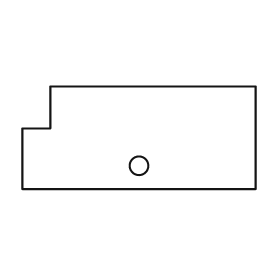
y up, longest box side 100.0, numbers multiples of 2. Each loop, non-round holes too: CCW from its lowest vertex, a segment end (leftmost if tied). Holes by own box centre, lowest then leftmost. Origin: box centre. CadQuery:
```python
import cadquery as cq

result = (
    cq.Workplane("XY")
    .moveTo(-50.0, -22.0)
    .lineTo(50.0, -22.0)
    .lineTo(50.0, 22.0)
    .lineTo(-38.0, 22.0)
    .lineTo(-38.0, 4.0)
    .lineTo(-50.0, 4.0)
    .close()
    .moveTo(0.0, -12.0)
    .circle(4.0)
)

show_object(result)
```